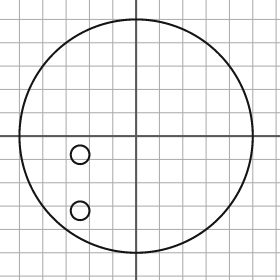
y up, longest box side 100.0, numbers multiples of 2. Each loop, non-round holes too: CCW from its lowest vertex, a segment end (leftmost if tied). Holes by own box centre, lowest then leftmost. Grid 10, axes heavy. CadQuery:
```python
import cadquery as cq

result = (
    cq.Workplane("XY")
    .moveTo(0.0, 0.0)
    .circle(50.0)
    .moveTo(-24.0, -32.0)
    .circle(4.0)
    .moveTo(-24.0, -8.0)
    .circle(4.0)
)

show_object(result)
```